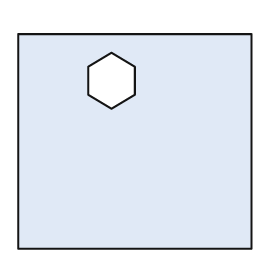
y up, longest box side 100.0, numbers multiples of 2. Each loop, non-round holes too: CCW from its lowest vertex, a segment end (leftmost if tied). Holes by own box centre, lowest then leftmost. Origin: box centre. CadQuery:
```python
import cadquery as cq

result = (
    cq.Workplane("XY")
    .moveTo(-50.0, -46.0)
    .lineTo(50.0, -46.0)
    .lineTo(50.0, 46.0)
    .lineTo(-50.0, 46.0)
    .close()
    .moveTo(-10.0, 14.0)
    .lineTo(0.0, 20.0)
    .lineTo(0.0, 32.0)
    .lineTo(-10.0, 38.0)
    .lineTo(-20.0, 32.0)
    .lineTo(-20.0, 20.0)
    .close()
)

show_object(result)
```